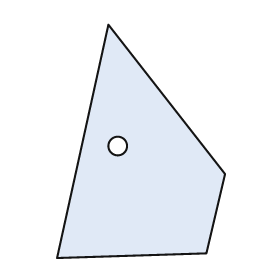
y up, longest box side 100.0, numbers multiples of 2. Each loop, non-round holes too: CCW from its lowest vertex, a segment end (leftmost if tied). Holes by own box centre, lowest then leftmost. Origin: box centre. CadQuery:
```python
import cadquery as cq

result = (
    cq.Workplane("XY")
    .moveTo(-36.0, -50.0)
    .lineTo(28.0, -48.0)
    .lineTo(36.0, -14.0)
    .lineTo(-14.0, 50.0)
    .close()
    .moveTo(-10.0, -2.0)
    .circle(4.0)
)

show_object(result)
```